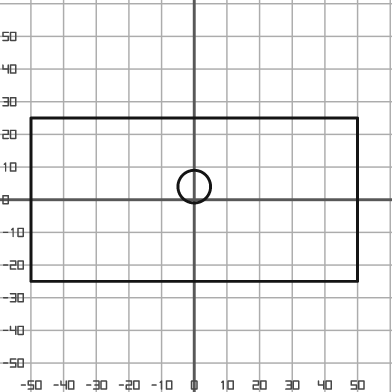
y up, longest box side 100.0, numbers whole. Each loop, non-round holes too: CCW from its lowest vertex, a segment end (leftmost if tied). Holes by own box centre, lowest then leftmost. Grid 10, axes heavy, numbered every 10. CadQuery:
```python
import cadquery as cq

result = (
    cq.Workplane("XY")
    .moveTo(-50.0, -25.0)
    .lineTo(50.0, -25.0)
    .lineTo(50.0, 25.0)
    .lineTo(-50.0, 25.0)
    .close()
    .moveTo(0.0, 4.0)
    .circle(5.0)
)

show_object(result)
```